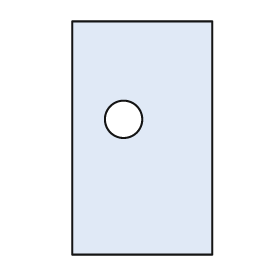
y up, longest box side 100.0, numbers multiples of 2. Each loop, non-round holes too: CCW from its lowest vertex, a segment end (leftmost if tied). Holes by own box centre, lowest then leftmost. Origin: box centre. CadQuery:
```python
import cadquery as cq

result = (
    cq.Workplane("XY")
    .moveTo(-30.0, -50.0)
    .lineTo(30.0, -50.0)
    .lineTo(30.0, 50.0)
    .lineTo(-30.0, 50.0)
    .close()
    .moveTo(-8.0, 8.0)
    .circle(8.0)
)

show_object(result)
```